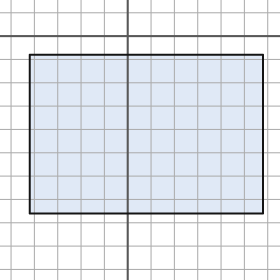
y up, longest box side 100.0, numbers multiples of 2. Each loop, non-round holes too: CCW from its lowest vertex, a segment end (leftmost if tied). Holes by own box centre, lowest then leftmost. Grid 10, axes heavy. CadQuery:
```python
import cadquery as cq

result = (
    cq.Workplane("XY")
    .moveTo(-42.0, -76.0)
    .lineTo(58.0, -76.0)
    .lineTo(58.0, -8.0)
    .lineTo(-42.0, -8.0)
    .close()
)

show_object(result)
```